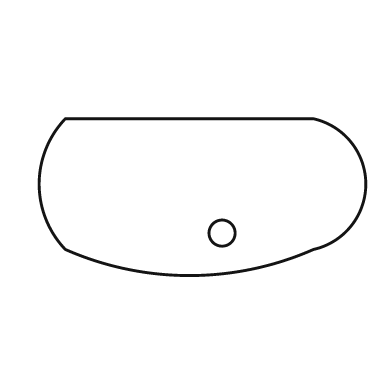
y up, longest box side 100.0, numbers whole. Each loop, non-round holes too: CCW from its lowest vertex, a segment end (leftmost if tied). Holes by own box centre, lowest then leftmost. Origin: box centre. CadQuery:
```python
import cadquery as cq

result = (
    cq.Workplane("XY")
    .moveTo(-42.0, -16.0)
    .threePointArc((-4.0, -24.0), (34.0, -16.0))
    .threePointArc((50.0, 4.0), (34.0, 24.0))
    .lineTo(-42.0, 24.0)
    .threePointArc((-50.0, 4.0), (-42.0, -16.0))
    .close()
    .moveTo(6.0, -11.0)
    .circle(4.0)
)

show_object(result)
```